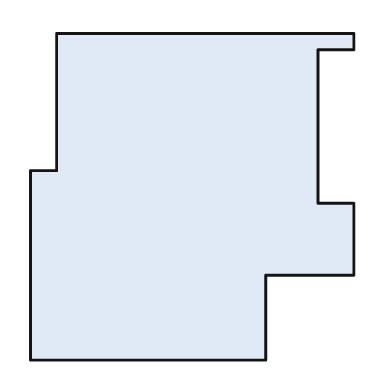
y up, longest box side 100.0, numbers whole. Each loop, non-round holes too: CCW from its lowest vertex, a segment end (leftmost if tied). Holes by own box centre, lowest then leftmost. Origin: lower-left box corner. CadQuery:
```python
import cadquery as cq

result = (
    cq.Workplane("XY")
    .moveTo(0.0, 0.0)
    .lineTo(72.0, 0.0)
    .lineTo(72.0, 26.0)
    .lineTo(99.0, 26.0)
    .lineTo(99.0, 48.0)
    .lineTo(88.0, 48.0)
    .lineTo(88.0, 95.0)
    .lineTo(99.0, 95.0)
    .lineTo(99.0, 100.0)
    .lineTo(8.0, 100.0)
    .lineTo(8.0, 58.0)
    .lineTo(0.0, 58.0)
    .close()
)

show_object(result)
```